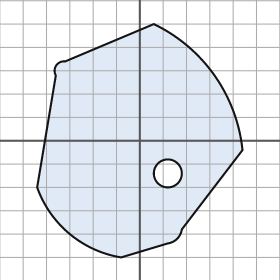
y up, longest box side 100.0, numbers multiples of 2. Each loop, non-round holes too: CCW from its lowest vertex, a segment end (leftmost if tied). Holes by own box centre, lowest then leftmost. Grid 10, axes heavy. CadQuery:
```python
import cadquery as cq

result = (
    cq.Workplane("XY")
    .moveTo(-8.0, -50.0)
    .lineTo(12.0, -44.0)
    .threePointArc((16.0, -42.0), (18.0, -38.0))
    .lineTo(44.0, -4.0)
    .threePointArc((32.0, 28.0), (6.0, 50.0))
    .lineTo(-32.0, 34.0)
    .threePointArc((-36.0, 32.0), (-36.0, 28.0))
    .lineTo(-44.0, -20.0)
    .threePointArc((-30.0, -40.0), (-8.0, -50.0))
    .close()
    .moveTo(12.0, -14.0)
    .circle(6.0)
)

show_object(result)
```